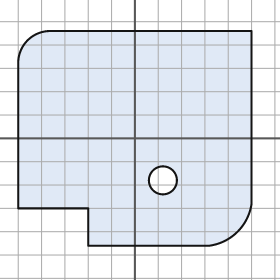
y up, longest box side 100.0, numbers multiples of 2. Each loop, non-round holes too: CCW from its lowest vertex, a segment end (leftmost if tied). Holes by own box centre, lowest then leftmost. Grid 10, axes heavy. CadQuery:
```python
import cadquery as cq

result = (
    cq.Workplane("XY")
    .moveTo(-20.0, -46.0)
    .lineTo(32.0, -46.0)
    .threePointArc((44.0, -40.0), (50.0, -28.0))
    .lineTo(50.0, 46.0)
    .lineTo(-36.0, 46.0)
    .threePointArc((-46.0, 42.0), (-50.0, 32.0))
    .lineTo(-50.0, -30.0)
    .lineTo(-20.0, -30.0)
    .close()
    .moveTo(12.0, -18.0)
    .circle(6.0)
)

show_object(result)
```